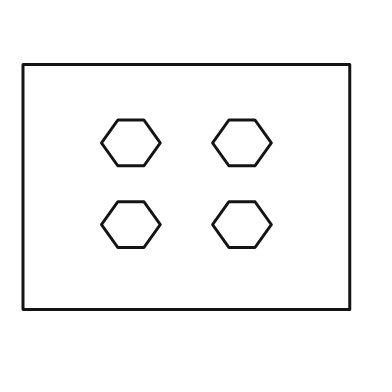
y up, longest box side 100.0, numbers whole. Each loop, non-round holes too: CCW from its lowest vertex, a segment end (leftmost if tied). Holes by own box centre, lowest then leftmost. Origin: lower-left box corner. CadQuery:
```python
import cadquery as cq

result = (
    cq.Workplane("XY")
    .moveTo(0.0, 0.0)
    .lineTo(100.0, 0.0)
    .lineTo(100.0, 75.0)
    .lineTo(0.0, 75.0)
    .close()
    .moveTo(29.0, 19.0)
    .lineTo(37.0, 19.0)
    .lineTo(42.0, 26.0)
    .lineTo(37.0, 33.0)
    .lineTo(29.0, 33.0)
    .lineTo(24.0, 26.0)
    .close()
    .moveTo(63.0, 19.0)
    .lineTo(71.0, 19.0)
    .lineTo(76.0, 26.0)
    .lineTo(71.0, 33.0)
    .lineTo(63.0, 33.0)
    .lineTo(58.0, 26.0)
    .close()
    .moveTo(29.0, 44.0)
    .lineTo(37.0, 44.0)
    .lineTo(42.0, 51.0)
    .lineTo(37.0, 58.0)
    .lineTo(29.0, 58.0)
    .lineTo(24.0, 51.0)
    .close()
    .moveTo(63.0, 44.0)
    .lineTo(71.0, 44.0)
    .lineTo(76.0, 51.0)
    .lineTo(71.0, 58.0)
    .lineTo(63.0, 58.0)
    .lineTo(58.0, 51.0)
    .close()
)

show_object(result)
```